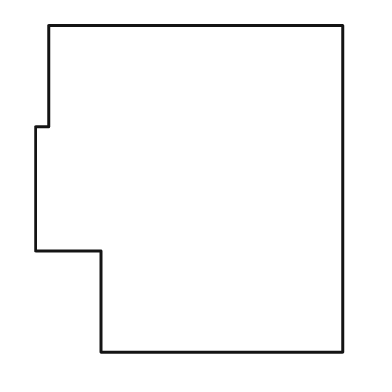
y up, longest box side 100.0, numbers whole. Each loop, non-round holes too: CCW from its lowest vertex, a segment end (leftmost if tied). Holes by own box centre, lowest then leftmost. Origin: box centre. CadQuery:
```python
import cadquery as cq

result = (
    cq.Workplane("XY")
    .moveTo(-27.0, -50.0)
    .lineTo(47.0, -50.0)
    .lineTo(47.0, 50.0)
    .lineTo(-43.0, 50.0)
    .lineTo(-43.0, 19.0)
    .lineTo(-47.0, 19.0)
    .lineTo(-47.0, -19.0)
    .lineTo(-27.0, -19.0)
    .close()
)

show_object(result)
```